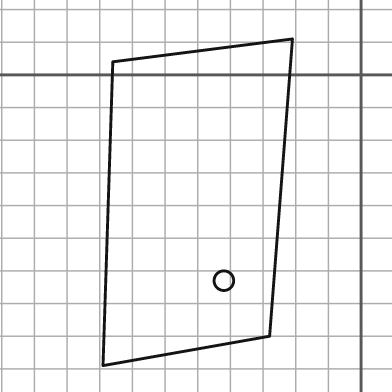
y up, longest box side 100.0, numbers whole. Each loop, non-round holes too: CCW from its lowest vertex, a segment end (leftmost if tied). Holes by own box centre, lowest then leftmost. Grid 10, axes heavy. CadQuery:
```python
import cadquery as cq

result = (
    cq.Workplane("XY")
    .moveTo(-79.0, -89.0)
    .lineTo(-28.0, -80.0)
    .lineTo(-21.0, 11.0)
    .lineTo(-76.0, 4.0)
    .close()
    .moveTo(-42.0, -63.0)
    .circle(3.0)
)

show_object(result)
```